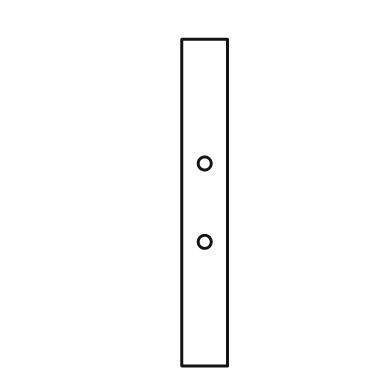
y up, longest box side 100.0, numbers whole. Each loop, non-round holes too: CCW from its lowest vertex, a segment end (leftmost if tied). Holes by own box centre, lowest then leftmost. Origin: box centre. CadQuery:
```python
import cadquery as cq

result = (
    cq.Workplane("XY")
    .moveTo(-7.0, -50.0)
    .lineTo(7.0, -50.0)
    .lineTo(7.0, 50.0)
    .lineTo(-7.0, 50.0)
    .close()
    .moveTo(0.0, -12.0)
    .circle(2.0)
    .moveTo(0.0, 12.0)
    .circle(2.0)
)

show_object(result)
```